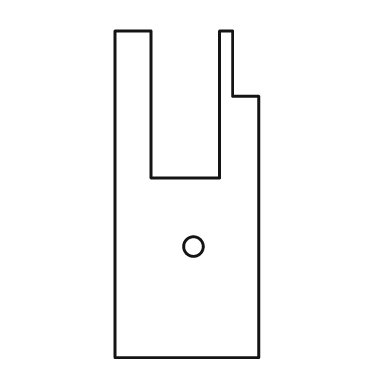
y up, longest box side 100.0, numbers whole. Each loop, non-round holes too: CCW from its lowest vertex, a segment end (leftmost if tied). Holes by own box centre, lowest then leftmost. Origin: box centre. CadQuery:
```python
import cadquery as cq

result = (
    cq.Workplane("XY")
    .moveTo(-22.0, -50.0)
    .lineTo(22.0, -50.0)
    .lineTo(22.0, 30.0)
    .lineTo(14.0, 30.0)
    .lineTo(14.0, 50.0)
    .lineTo(10.0, 50.0)
    .lineTo(10.0, 5.0)
    .lineTo(-11.0, 5.0)
    .lineTo(-11.0, 50.0)
    .lineTo(-22.0, 50.0)
    .close()
    .moveTo(2.0, -16.0)
    .circle(3.0)
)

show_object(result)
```